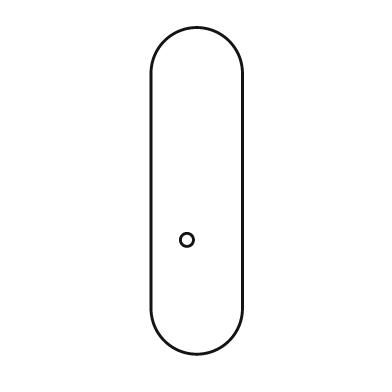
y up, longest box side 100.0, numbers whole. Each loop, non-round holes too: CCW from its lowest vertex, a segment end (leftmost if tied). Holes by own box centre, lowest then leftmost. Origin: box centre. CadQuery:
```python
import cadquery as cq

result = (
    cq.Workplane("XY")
    .moveTo(-14.0, -36.0)
    .threePointArc((0.0, -50.0), (14.0, -36.0))
    .lineTo(14.0, 36.0)
    .threePointArc((0.0, 50.0), (-14.0, 36.0))
    .close()
    .moveTo(-3.0, -15.0)
    .circle(2.0)
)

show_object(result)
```